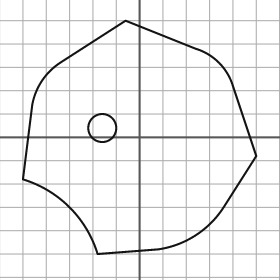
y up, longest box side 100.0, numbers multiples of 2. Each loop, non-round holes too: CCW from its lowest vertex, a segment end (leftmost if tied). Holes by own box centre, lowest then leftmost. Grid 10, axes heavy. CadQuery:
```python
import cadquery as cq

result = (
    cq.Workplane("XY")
    .moveTo(-18.0, -50.0)
    .lineTo(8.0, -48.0)
    .threePointArc((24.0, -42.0), (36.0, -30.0))
    .lineTo(50.0, -8.0)
    .lineTo(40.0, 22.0)
    .threePointArc((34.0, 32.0), (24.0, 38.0))
    .lineTo(-6.0, 50.0)
    .lineTo(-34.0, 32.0)
    .threePointArc((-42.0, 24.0), (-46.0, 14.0))
    .lineTo(-50.0, -18.0)
    .threePointArc((-30.0, -30.0), (-18.0, -50.0))
    .close()
    .moveTo(-16.0, 4.0)
    .circle(6.0)
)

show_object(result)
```